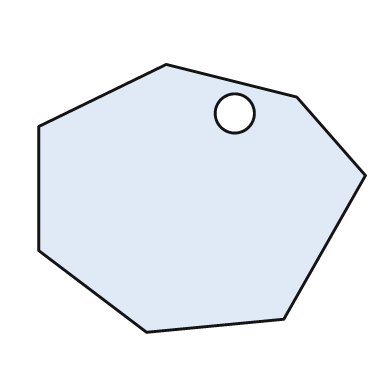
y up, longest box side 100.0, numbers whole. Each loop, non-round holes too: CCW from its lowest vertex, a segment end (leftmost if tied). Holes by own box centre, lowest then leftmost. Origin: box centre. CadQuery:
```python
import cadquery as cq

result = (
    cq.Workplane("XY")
    .moveTo(-17.0, -41.0)
    .lineTo(25.0, -37.0)
    .lineTo(50.0, 7.0)
    .lineTo(29.0, 31.0)
    .lineTo(-11.0, 41.0)
    .lineTo(-50.0, 22.0)
    .lineTo(-50.0, -16.0)
    .close()
    .moveTo(10.0, 26.0)
    .circle(6.0)
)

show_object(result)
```